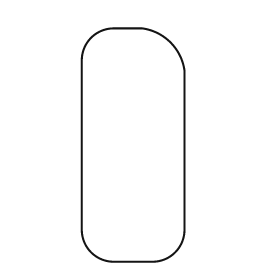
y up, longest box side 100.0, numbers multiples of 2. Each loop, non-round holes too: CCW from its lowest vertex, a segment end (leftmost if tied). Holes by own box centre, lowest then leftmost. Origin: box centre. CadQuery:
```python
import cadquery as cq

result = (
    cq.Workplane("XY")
    .moveTo(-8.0, -50.0)
    .lineTo(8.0, -50.0)
    .threePointArc((18.0, -46.0), (22.0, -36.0))
    .lineTo(22.0, 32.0)
    .threePointArc((16.0, 44.0), (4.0, 50.0))
    .lineTo(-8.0, 50.0)
    .threePointArc((-18.0, 46.0), (-22.0, 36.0))
    .lineTo(-22.0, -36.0)
    .threePointArc((-18.0, -46.0), (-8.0, -50.0))
    .close()
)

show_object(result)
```